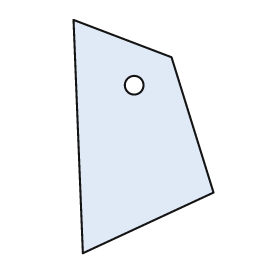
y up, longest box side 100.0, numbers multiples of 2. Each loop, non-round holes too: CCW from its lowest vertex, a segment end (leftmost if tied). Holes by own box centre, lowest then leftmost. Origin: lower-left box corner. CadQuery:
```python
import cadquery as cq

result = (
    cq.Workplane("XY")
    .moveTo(4.0, 0.0)
    .lineTo(60.0, 26.0)
    .lineTo(42.0, 84.0)
    .lineTo(0.0, 100.0)
    .close()
    .moveTo(26.0, 72.0)
    .circle(4.0)
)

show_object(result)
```